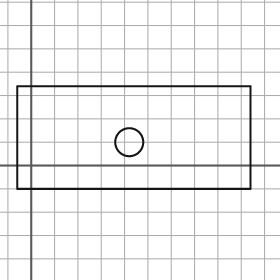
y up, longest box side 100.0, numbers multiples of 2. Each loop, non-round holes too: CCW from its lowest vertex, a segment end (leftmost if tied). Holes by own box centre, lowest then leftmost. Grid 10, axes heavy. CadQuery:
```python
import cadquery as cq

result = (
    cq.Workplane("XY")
    .moveTo(-6.0, -10.0)
    .lineTo(94.0, -10.0)
    .lineTo(94.0, 34.0)
    .lineTo(-6.0, 34.0)
    .close()
    .moveTo(42.0, 10.0)
    .circle(6.0)
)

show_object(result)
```